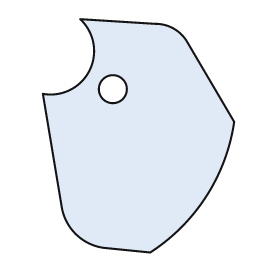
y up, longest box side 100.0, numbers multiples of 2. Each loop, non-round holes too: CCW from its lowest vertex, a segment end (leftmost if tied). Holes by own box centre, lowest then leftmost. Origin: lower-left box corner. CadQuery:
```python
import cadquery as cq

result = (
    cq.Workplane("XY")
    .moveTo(46.0, 0.0)
    .threePointArc((70.0, 24.0), (82.0, 56.0))
    .lineTo(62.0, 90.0)
    .threePointArc((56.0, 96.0), (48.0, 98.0))
    .lineTo(16.0, 100.0)
    .threePointArc((20.0, 78.0), (0.0, 68.0))
    .lineTo(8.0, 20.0)
    .threePointArc((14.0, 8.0), (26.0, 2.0))
    .close()
    .moveTo(30.0, 70.0)
    .circle(6.0)
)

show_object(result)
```